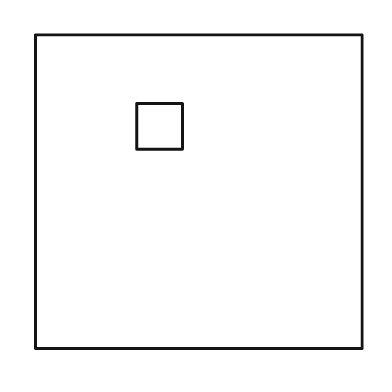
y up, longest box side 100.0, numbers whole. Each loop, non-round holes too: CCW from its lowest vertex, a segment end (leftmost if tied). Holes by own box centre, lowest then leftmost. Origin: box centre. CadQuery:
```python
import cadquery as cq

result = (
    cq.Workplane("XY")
    .moveTo(-50.0, -48.0)
    .lineTo(50.0, -48.0)
    .lineTo(50.0, 48.0)
    .lineTo(-50.0, 48.0)
    .close()
    .moveTo(-19.0, 13.0)
    .lineTo(-5.0, 13.0)
    .lineTo(-5.0, 27.0)
    .lineTo(-19.0, 27.0)
    .close()
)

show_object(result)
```